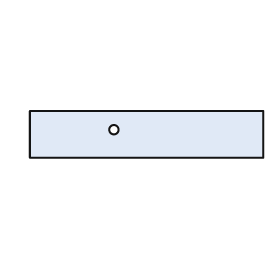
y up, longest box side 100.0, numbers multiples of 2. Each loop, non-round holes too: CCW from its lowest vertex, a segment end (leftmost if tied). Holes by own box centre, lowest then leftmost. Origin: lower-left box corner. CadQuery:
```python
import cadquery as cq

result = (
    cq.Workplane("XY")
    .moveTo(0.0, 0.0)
    .lineTo(100.0, 0.0)
    .lineTo(100.0, 20.0)
    .lineTo(0.0, 20.0)
    .close()
    .moveTo(36.0, 12.0)
    .circle(2.0)
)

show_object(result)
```